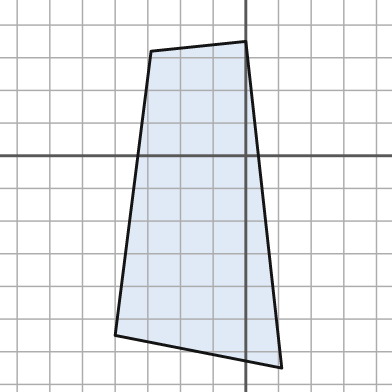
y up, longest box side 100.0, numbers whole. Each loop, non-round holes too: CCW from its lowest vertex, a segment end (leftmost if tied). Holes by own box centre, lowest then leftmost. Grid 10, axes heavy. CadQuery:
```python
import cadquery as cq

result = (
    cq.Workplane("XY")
    .moveTo(11.0, -65.0)
    .lineTo(0.0, 35.0)
    .lineTo(-29.0, 32.0)
    .lineTo(-40.0, -55.0)
    .close()
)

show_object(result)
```